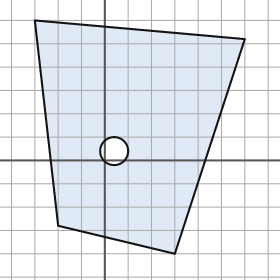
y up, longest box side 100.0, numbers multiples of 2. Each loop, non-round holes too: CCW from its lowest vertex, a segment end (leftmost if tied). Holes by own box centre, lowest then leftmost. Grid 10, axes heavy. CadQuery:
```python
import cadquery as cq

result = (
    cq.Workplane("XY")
    .moveTo(30.0, -40.0)
    .lineTo(60.0, 52.0)
    .lineTo(-30.0, 60.0)
    .lineTo(-20.0, -28.0)
    .close()
    .moveTo(4.0, 4.0)
    .circle(6.0)
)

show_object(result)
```